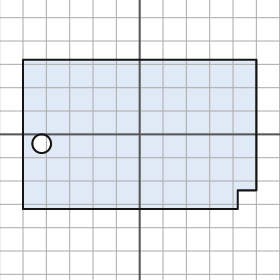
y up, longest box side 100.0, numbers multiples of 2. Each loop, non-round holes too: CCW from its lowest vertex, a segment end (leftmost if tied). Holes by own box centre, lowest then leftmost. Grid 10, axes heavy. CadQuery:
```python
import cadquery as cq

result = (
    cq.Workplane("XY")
    .moveTo(-50.0, -32.0)
    .lineTo(42.0, -32.0)
    .lineTo(42.0, -24.0)
    .lineTo(50.0, -24.0)
    .lineTo(50.0, 32.0)
    .lineTo(-50.0, 32.0)
    .close()
    .moveTo(-42.0, -4.0)
    .circle(4.0)
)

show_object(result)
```